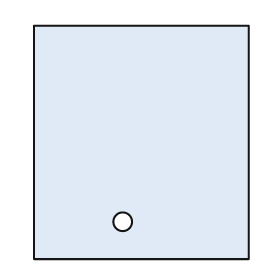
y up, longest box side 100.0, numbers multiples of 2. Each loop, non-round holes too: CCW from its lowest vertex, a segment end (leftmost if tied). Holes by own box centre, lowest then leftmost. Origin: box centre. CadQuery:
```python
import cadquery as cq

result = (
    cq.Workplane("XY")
    .moveTo(-46.0, -50.0)
    .lineTo(46.0, -50.0)
    .lineTo(46.0, 50.0)
    .lineTo(-46.0, 50.0)
    .close()
    .moveTo(-8.0, -34.0)
    .circle(4.0)
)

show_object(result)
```